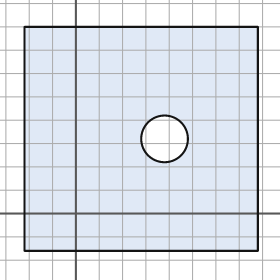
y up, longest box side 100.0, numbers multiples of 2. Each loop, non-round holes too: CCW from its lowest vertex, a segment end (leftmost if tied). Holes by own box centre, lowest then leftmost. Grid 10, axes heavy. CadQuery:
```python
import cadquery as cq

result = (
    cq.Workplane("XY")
    .moveTo(-22.0, -16.0)
    .lineTo(78.0, -16.0)
    .lineTo(78.0, 80.0)
    .lineTo(-22.0, 80.0)
    .close()
    .moveTo(38.0, 32.0)
    .circle(10.0)
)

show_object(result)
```